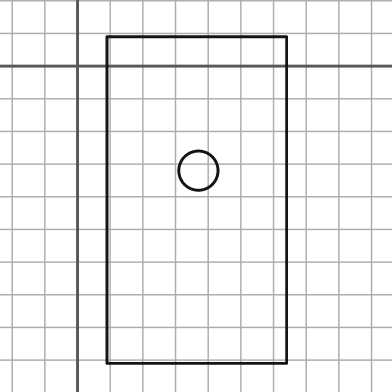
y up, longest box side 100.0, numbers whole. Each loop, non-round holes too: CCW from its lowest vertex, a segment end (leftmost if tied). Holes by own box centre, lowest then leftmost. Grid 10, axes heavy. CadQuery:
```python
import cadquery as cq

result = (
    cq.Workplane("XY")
    .moveTo(9.0, -91.0)
    .lineTo(64.0, -91.0)
    .lineTo(64.0, 9.0)
    .lineTo(9.0, 9.0)
    .close()
    .moveTo(37.0, -32.0)
    .circle(6.0)
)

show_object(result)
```